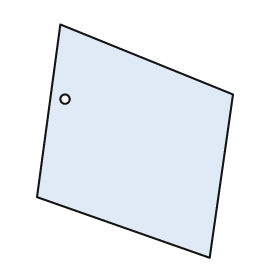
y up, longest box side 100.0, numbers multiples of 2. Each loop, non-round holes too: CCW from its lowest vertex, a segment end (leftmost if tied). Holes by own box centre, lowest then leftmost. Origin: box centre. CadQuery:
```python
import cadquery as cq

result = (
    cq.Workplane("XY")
    .moveTo(32.0, -50.0)
    .lineTo(42.0, 20.0)
    .lineTo(-32.0, 50.0)
    .lineTo(-42.0, -24.0)
    .close()
    .moveTo(-30.0, 18.0)
    .circle(2.0)
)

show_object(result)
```